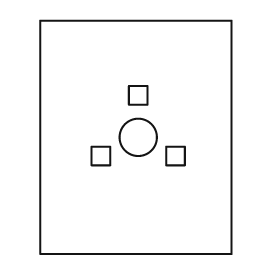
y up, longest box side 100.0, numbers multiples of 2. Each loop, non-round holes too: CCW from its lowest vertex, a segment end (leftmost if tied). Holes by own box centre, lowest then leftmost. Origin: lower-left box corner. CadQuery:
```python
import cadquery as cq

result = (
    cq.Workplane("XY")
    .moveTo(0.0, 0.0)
    .lineTo(82.0, 0.0)
    .lineTo(82.0, 100.0)
    .lineTo(0.0, 100.0)
    .close()
    .moveTo(22.0, 38.0)
    .lineTo(30.0, 38.0)
    .lineTo(30.0, 46.0)
    .lineTo(22.0, 46.0)
    .close()
    .moveTo(54.0, 38.0)
    .lineTo(62.0, 38.0)
    .lineTo(62.0, 46.0)
    .lineTo(54.0, 46.0)
    .close()
    .moveTo(42.0, 50.0)
    .circle(8.0)
    .moveTo(38.0, 64.0)
    .lineTo(46.0, 64.0)
    .lineTo(46.0, 72.0)
    .lineTo(38.0, 72.0)
    .close()
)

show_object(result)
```